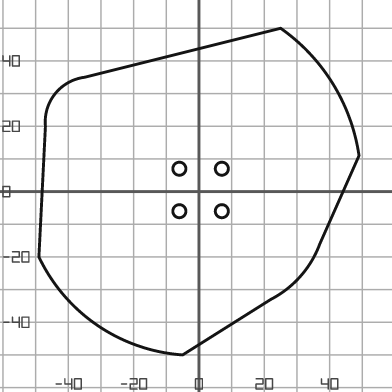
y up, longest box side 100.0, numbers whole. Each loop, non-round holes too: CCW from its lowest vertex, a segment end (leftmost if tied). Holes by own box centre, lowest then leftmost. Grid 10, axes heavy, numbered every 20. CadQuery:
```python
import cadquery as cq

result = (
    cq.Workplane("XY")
    .moveTo(-5.0, -50.0)
    .lineTo(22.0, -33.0)
    .threePointArc((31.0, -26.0), (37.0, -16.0))
    .lineTo(49.0, 11.0)
    .threePointArc((41.0, 33.0), (25.0, 50.0))
    .lineTo(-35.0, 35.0)
    .threePointArc((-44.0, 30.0), (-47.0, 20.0))
    .lineTo(-49.0, -20.0)
    .threePointArc((-31.0, -41.0), (-5.0, -50.0))
    .close()
    .moveTo(-6.0, -6.0)
    .circle(2.0)
    .moveTo(7.0, -6.0)
    .circle(2.0)
    .moveTo(-6.0, 7.0)
    .circle(2.0)
    .moveTo(7.0, 7.0)
    .circle(2.0)
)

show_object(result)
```